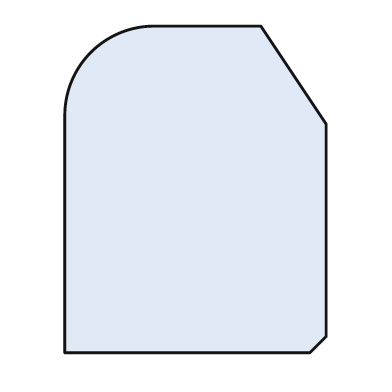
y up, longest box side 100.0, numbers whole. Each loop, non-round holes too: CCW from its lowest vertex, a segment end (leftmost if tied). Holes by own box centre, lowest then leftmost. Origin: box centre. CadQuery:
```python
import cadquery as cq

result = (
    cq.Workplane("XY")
    .moveTo(-40.0, -50.0)
    .lineTo(35.0, -50.0)
    .lineTo(40.0, -45.0)
    .lineTo(40.0, 20.0)
    .lineTo(20.0, 50.0)
    .lineTo(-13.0, 50.0)
    .threePointArc((-32.0, 42.0), (-40.0, 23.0))
    .close()
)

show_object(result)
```